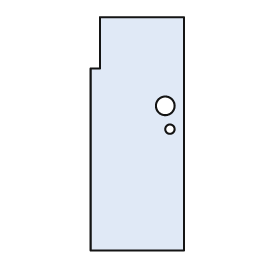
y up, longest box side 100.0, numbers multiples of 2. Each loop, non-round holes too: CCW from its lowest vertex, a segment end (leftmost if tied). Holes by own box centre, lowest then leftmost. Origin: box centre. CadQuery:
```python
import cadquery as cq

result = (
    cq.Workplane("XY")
    .moveTo(-20.0, -50.0)
    .lineTo(20.0, -50.0)
    .lineTo(20.0, 50.0)
    .lineTo(-16.0, 50.0)
    .lineTo(-16.0, 28.0)
    .lineTo(-20.0, 28.0)
    .close()
    .moveTo(14.0, 2.0)
    .circle(2.0)
    .moveTo(12.0, 12.0)
    .circle(4.0)
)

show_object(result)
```